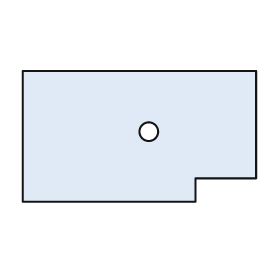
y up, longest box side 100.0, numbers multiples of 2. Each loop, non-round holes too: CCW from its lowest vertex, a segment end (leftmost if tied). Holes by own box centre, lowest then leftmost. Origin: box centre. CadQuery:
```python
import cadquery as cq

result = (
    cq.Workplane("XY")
    .moveTo(-50.0, -28.0)
    .lineTo(24.0, -28.0)
    .lineTo(24.0, -18.0)
    .lineTo(50.0, -18.0)
    .lineTo(50.0, 28.0)
    .lineTo(-50.0, 28.0)
    .close()
    .moveTo(4.0, 2.0)
    .circle(4.0)
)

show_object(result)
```